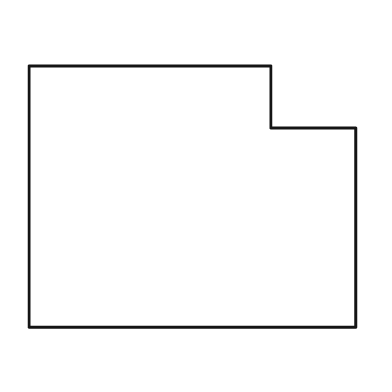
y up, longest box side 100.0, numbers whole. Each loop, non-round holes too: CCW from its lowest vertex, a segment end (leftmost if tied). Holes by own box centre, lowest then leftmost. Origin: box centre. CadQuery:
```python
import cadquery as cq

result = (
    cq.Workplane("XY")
    .moveTo(-50.0, -40.0)
    .lineTo(50.0, -40.0)
    .lineTo(50.0, 21.0)
    .lineTo(24.0, 21.0)
    .lineTo(24.0, 40.0)
    .lineTo(-50.0, 40.0)
    .close()
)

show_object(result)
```